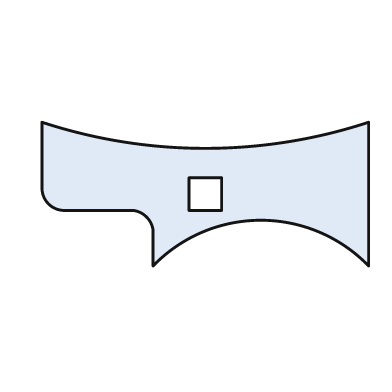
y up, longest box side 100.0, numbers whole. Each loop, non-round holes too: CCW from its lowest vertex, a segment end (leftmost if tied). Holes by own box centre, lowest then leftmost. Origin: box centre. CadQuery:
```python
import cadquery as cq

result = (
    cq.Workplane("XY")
    .moveTo(-16.0, -22.0)
    .threePointArc((17.0, -8.0), (50.0, -22.0))
    .lineTo(50.0, 22.0)
    .threePointArc((0.0, 14.0), (-50.0, 22.0))
    .lineTo(-50.0, 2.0)
    .threePointArc((-48.0, -3.0), (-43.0, -5.0))
    .lineTo(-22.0, -5.0)
    .threePointArc((-18.0, -7.0), (-16.0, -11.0))
    .close()
    .moveTo(-5.0, -5.0)
    .lineTo(5.0, -5.0)
    .lineTo(5.0, 5.0)
    .lineTo(-5.0, 5.0)
    .close()
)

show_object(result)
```